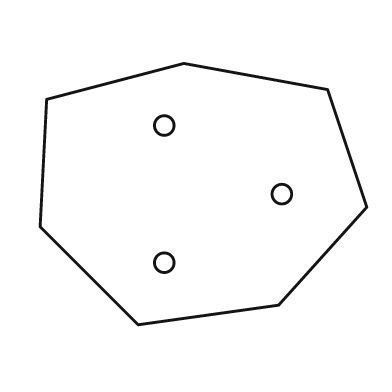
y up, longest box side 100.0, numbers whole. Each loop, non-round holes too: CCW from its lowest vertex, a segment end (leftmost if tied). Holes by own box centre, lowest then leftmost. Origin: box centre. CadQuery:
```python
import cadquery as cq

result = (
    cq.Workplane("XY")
    .moveTo(-20.0, -40.0)
    .lineTo(23.0, -34.0)
    .lineTo(50.0, -4.0)
    .lineTo(38.0, 32.0)
    .lineTo(-6.0, 40.0)
    .lineTo(-48.0, 29.0)
    .lineTo(-50.0, -10.0)
    .close()
    .moveTo(-12.0, -21.0)
    .circle(3.0)
    .moveTo(24.0, 0.0)
    .circle(3.0)
    .moveTo(-12.0, 21.0)
    .circle(3.0)
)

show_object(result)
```